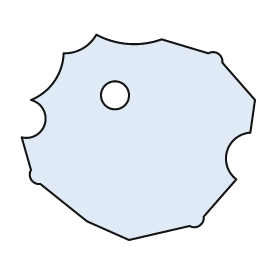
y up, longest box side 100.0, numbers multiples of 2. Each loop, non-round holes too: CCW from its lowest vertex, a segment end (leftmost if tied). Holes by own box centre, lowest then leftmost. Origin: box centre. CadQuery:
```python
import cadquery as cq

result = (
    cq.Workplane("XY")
    .moveTo(-4.0, -44.0)
    .lineTo(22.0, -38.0)
    .threePointArc((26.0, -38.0), (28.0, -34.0))
    .lineTo(42.0, -18.0)
    .threePointArc((38.0, -6.0), (48.0, 2.0))
    .lineTo(50.0, 16.0)
    .lineTo(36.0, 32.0)
    .threePointArc((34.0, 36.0), (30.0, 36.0))
    .lineTo(10.0, 42.0)
    .threePointArc((-4.0, 40.0), (-18.0, 44.0))
    .threePointArc((-24.0, 38.0), (-32.0, 36.0))
    .threePointArc((-36.0, 24.0), (-46.0, 16.0))
    .threePointArc((-40.0, 6.0), (-50.0, 0.0))
    .lineTo(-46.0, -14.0)
    .threePointArc((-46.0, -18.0), (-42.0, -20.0))
    .lineTo(-22.0, -36.0)
    .close()
    .moveTo(-10.0, 18.0)
    .circle(6.0)
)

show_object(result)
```